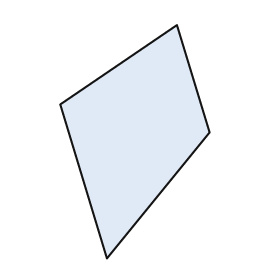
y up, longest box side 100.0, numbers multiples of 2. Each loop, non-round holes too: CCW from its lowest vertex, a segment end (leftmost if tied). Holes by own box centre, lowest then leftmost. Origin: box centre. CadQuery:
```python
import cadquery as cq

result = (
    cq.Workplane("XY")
    .moveTo(-12.0, -50.0)
    .lineTo(32.0, 4.0)
    .lineTo(18.0, 50.0)
    .lineTo(-32.0, 16.0)
    .close()
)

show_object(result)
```